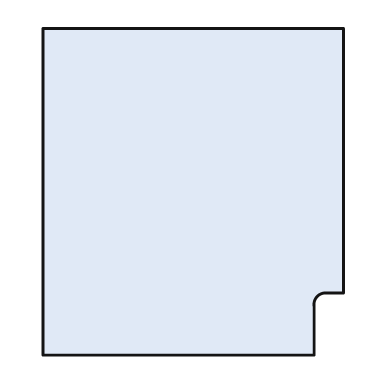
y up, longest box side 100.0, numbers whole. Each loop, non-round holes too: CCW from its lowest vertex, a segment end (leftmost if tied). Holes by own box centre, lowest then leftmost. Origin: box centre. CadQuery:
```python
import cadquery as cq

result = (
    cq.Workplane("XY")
    .moveTo(-46.0, -50.0)
    .lineTo(37.0, -50.0)
    .lineTo(37.0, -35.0)
    .threePointArc((38.0, -32.0), (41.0, -31.0))
    .lineTo(46.0, -31.0)
    .lineTo(46.0, 50.0)
    .lineTo(-46.0, 50.0)
    .close()
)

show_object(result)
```